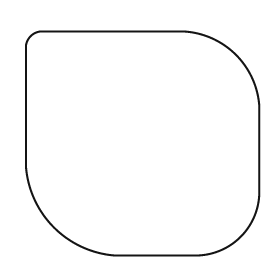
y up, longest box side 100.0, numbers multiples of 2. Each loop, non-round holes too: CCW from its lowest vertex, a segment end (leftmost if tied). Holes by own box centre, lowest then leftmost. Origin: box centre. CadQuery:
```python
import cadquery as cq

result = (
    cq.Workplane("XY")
    .moveTo(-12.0, -48.0)
    .lineTo(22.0, -48.0)
    .threePointArc((42.0, -40.0), (50.0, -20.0))
    .lineTo(50.0, 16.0)
    .threePointArc((40.0, 38.0), (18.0, 48.0))
    .lineTo(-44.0, 48.0)
    .threePointArc((-48.0, 46.0), (-50.0, 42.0))
    .lineTo(-50.0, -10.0)
    .threePointArc((-38.0, -36.0), (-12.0, -48.0))
    .close()
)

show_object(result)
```